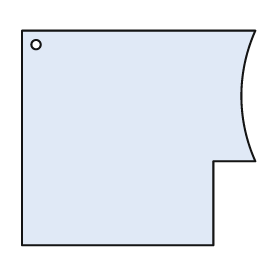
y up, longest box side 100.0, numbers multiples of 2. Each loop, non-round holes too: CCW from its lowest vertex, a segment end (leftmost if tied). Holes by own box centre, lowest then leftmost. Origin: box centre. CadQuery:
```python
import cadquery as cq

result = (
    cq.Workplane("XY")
    .moveTo(-50.0, -46.0)
    .lineTo(32.0, -46.0)
    .lineTo(32.0, -10.0)
    .lineTo(50.0, -10.0)
    .threePointArc((44.0, 18.0), (50.0, 46.0))
    .lineTo(-50.0, 46.0)
    .close()
    .moveTo(-44.0, 40.0)
    .circle(2.0)
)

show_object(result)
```